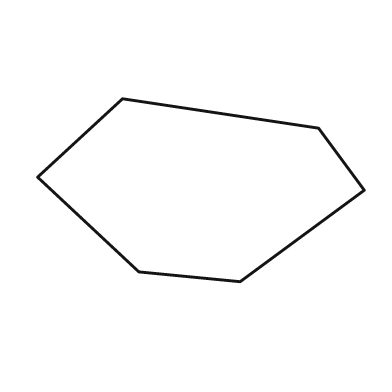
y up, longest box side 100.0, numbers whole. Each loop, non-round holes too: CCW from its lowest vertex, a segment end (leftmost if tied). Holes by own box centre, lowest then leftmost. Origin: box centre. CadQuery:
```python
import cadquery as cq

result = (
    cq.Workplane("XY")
    .moveTo(12.0, -28.0)
    .lineTo(50.0, 0.0)
    .lineTo(36.0, 19.0)
    .lineTo(-24.0, 28.0)
    .lineTo(-50.0, 4.0)
    .lineTo(-19.0, -25.0)
    .close()
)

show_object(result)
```